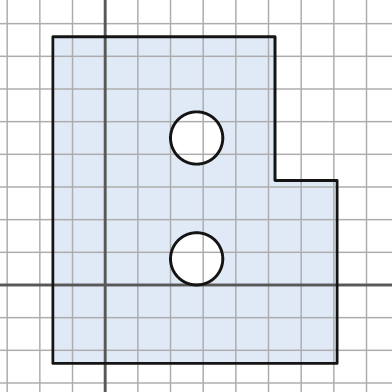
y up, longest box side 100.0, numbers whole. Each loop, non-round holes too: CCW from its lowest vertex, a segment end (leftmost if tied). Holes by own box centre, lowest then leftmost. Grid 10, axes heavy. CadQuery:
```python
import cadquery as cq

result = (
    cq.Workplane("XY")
    .moveTo(-16.0, -24.0)
    .lineTo(71.0, -24.0)
    .lineTo(71.0, 32.0)
    .lineTo(52.0, 32.0)
    .lineTo(52.0, 76.0)
    .lineTo(-16.0, 76.0)
    .close()
    .moveTo(28.0, 8.0)
    .circle(8.0)
    .moveTo(28.0, 45.0)
    .circle(8.0)
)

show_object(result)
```